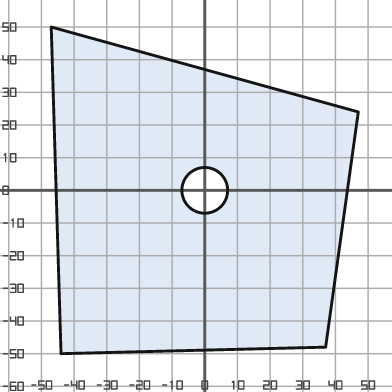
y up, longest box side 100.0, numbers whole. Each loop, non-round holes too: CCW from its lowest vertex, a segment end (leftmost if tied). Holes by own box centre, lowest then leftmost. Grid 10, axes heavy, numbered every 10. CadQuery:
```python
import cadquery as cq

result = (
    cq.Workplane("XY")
    .moveTo(-44.0, -50.0)
    .lineTo(37.0, -48.0)
    .lineTo(47.0, 24.0)
    .lineTo(-47.0, 50.0)
    .close()
    .moveTo(0.0, 0.0)
    .circle(7.0)
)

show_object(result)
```